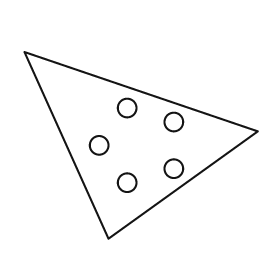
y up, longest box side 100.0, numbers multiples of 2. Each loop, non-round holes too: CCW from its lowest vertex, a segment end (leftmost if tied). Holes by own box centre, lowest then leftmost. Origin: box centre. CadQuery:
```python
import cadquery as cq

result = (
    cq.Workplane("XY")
    .moveTo(-14.0, -40.0)
    .lineTo(50.0, 6.0)
    .lineTo(-50.0, 40.0)
    .close()
    .moveTo(-6.0, -16.0)
    .circle(4.0)
    .moveTo(14.0, -10.0)
    .circle(4.0)
    .moveTo(-18.0, 0.0)
    .circle(4.0)
    .moveTo(14.0, 10.0)
    .circle(4.0)
    .moveTo(-6.0, 16.0)
    .circle(4.0)
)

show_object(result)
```